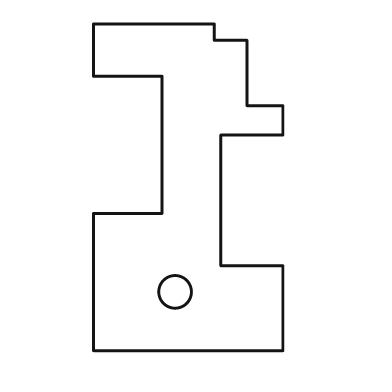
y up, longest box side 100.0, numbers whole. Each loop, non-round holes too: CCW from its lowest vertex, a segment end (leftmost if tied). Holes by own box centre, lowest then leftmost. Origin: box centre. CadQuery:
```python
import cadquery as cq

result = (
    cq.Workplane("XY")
    .moveTo(-29.0, -50.0)
    .lineTo(29.0, -50.0)
    .lineTo(29.0, -24.0)
    .lineTo(10.0, -24.0)
    .lineTo(10.0, 16.0)
    .lineTo(29.0, 16.0)
    .lineTo(29.0, 25.0)
    .lineTo(18.0, 25.0)
    .lineTo(18.0, 45.0)
    .lineTo(8.0, 45.0)
    .lineTo(8.0, 50.0)
    .lineTo(-29.0, 50.0)
    .lineTo(-29.0, 34.0)
    .lineTo(-8.0, 34.0)
    .lineTo(-8.0, -8.0)
    .lineTo(-29.0, -8.0)
    .close()
    .moveTo(-4.0, -32.0)
    .circle(5.0)
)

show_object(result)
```